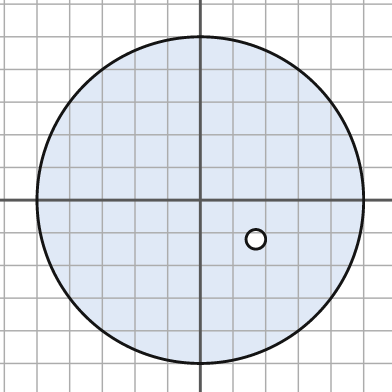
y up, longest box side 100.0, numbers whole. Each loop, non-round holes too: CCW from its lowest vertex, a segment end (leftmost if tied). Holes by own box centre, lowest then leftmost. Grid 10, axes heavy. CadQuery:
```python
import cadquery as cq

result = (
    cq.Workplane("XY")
    .moveTo(0.0, 0.0)
    .circle(50.0)
    .moveTo(17.0, -12.0)
    .circle(3.0)
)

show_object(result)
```